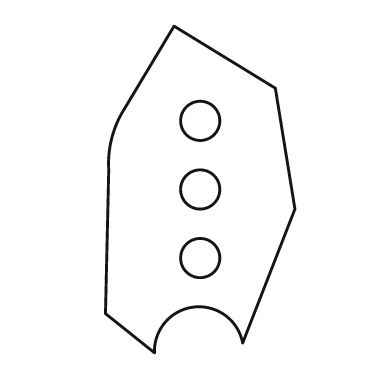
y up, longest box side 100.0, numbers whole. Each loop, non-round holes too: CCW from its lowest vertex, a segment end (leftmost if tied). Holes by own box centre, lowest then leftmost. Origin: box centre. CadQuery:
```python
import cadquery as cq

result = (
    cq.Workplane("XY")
    .moveTo(-14.0, -50.0)
    .threePointArc((-2.0, -36.0), (13.0, -47.0))
    .lineTo(29.0, -6.0)
    .lineTo(23.0, 31.0)
    .lineTo(-8.0, 50.0)
    .lineTo(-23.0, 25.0)
    .threePointArc((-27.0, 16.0), (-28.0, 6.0))
    .lineTo(-29.0, -38.0)
    .close()
    .moveTo(0.0, -21.0)
    .circle(6.0)
    .moveTo(0.0, 0.0)
    .circle(6.0)
    .moveTo(0.0, 21.0)
    .circle(6.0)
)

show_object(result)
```